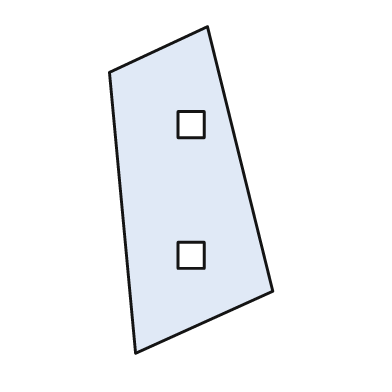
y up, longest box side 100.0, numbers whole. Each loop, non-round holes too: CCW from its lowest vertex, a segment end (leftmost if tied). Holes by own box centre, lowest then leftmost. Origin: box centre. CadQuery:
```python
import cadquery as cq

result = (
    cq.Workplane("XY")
    .moveTo(-17.0, -50.0)
    .lineTo(25.0, -31.0)
    .lineTo(5.0, 50.0)
    .lineTo(-25.0, 36.0)
    .close()
    .moveTo(-4.0, -24.0)
    .lineTo(4.0, -24.0)
    .lineTo(4.0, -16.0)
    .lineTo(-4.0, -16.0)
    .close()
    .moveTo(-4.0, 16.0)
    .lineTo(4.0, 16.0)
    .lineTo(4.0, 24.0)
    .lineTo(-4.0, 24.0)
    .close()
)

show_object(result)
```